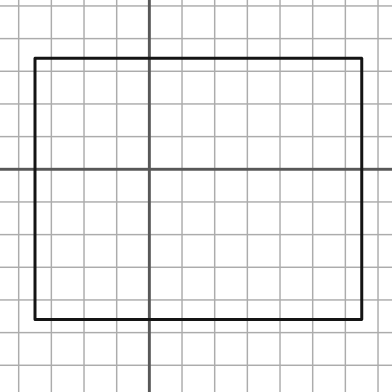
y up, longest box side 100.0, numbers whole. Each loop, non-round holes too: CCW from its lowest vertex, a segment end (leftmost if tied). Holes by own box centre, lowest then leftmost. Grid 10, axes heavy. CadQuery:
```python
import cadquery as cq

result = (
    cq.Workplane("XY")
    .moveTo(-35.0, -46.0)
    .lineTo(65.0, -46.0)
    .lineTo(65.0, 34.0)
    .lineTo(-35.0, 34.0)
    .close()
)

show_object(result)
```